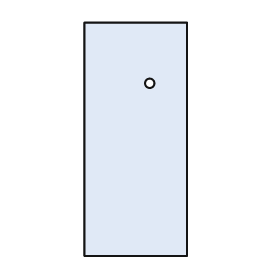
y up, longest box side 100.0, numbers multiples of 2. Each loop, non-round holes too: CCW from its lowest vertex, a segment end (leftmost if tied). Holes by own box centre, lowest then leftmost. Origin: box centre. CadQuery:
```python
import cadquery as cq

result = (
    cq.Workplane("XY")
    .moveTo(-22.0, -50.0)
    .lineTo(22.0, -50.0)
    .lineTo(22.0, 50.0)
    .lineTo(-22.0, 50.0)
    .close()
    .moveTo(6.0, 24.0)
    .circle(2.0)
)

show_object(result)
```